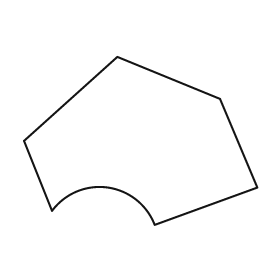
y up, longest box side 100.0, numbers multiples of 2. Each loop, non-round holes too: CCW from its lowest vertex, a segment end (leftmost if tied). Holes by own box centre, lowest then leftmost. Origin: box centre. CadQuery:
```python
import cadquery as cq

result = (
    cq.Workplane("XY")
    .moveTo(6.0, -36.0)
    .lineTo(50.0, -20.0)
    .lineTo(34.0, 18.0)
    .lineTo(-10.0, 36.0)
    .lineTo(-50.0, 0.0)
    .lineTo(-38.0, -30.0)
    .threePointArc((-14.0, -20.0), (6.0, -36.0))
    .close()
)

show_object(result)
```